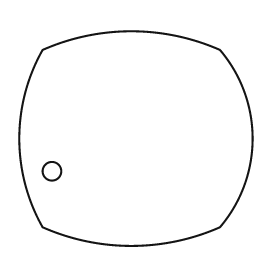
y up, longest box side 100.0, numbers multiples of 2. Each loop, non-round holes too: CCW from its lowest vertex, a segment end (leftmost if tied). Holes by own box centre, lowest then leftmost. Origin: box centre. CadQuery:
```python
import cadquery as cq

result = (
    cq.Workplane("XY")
    .moveTo(-40.0, -38.0)
    .threePointArc((-2.0, -46.0), (36.0, -38.0))
    .threePointArc((50.0, 0.0), (36.0, 38.0))
    .threePointArc((-2.0, 46.0), (-40.0, 38.0))
    .threePointArc((-50.0, 0.0), (-40.0, -38.0))
    .close()
    .moveTo(-36.0, -14.0)
    .circle(4.0)
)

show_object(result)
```